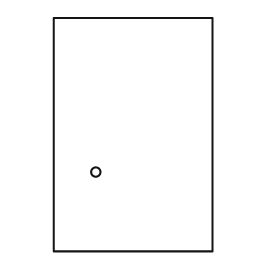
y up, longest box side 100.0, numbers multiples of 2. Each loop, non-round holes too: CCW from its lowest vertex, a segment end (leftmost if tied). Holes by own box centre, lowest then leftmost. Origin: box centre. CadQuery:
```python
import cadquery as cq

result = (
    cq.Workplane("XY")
    .moveTo(-34.0, -50.0)
    .lineTo(34.0, -50.0)
    .lineTo(34.0, 50.0)
    .lineTo(-34.0, 50.0)
    .close()
    .moveTo(-16.0, -16.0)
    .circle(2.0)
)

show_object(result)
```